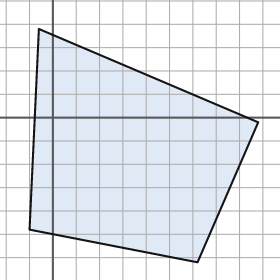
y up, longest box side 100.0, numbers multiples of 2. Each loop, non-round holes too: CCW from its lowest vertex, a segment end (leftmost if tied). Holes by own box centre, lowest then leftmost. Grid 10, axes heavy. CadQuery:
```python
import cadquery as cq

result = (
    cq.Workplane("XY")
    .moveTo(62.0, -62.0)
    .lineTo(88.0, -2.0)
    .lineTo(-6.0, 38.0)
    .lineTo(-10.0, -48.0)
    .close()
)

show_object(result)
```